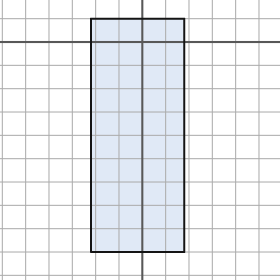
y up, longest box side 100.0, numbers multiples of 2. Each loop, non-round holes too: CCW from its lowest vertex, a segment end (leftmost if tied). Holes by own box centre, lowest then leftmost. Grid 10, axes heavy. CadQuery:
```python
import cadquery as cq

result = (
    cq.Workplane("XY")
    .moveTo(-22.0, -90.0)
    .lineTo(18.0, -90.0)
    .lineTo(18.0, 10.0)
    .lineTo(-22.0, 10.0)
    .close()
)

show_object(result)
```